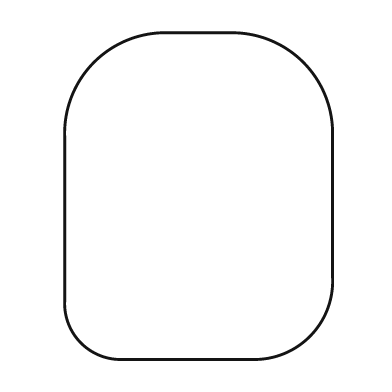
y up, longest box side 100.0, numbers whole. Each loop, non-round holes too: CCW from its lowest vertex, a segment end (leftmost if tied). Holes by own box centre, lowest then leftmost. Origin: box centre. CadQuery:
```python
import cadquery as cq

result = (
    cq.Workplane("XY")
    .moveTo(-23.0, -50.0)
    .lineTo(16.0, -50.0)
    .threePointArc((34.0, -43.0), (41.0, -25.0))
    .lineTo(41.0, 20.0)
    .threePointArc((32.0, 41.0), (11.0, 50.0))
    .lineTo(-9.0, 50.0)
    .threePointArc((-32.0, 41.0), (-41.0, 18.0))
    .lineTo(-41.0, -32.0)
    .threePointArc((-36.0, -45.0), (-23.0, -50.0))
    .close()
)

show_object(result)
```